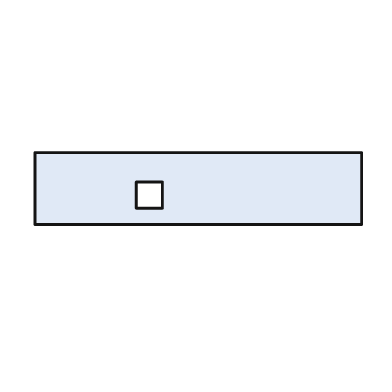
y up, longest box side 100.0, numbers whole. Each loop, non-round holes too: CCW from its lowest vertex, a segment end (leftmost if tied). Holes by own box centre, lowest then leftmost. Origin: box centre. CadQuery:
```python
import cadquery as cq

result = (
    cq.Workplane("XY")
    .moveTo(-50.0, -11.0)
    .lineTo(50.0, -11.0)
    .lineTo(50.0, 11.0)
    .lineTo(-50.0, 11.0)
    .close()
    .moveTo(-19.0, -6.0)
    .lineTo(-11.0, -6.0)
    .lineTo(-11.0, 2.0)
    .lineTo(-19.0, 2.0)
    .close()
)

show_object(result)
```